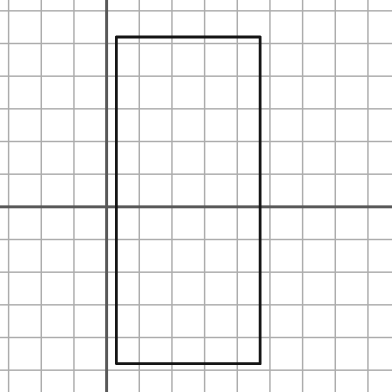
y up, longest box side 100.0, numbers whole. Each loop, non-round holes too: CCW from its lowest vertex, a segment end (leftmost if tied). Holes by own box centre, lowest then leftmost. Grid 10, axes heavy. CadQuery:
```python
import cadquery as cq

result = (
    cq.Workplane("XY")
    .moveTo(3.0, -48.0)
    .lineTo(47.0, -48.0)
    .lineTo(47.0, 52.0)
    .lineTo(3.0, 52.0)
    .close()
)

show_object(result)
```